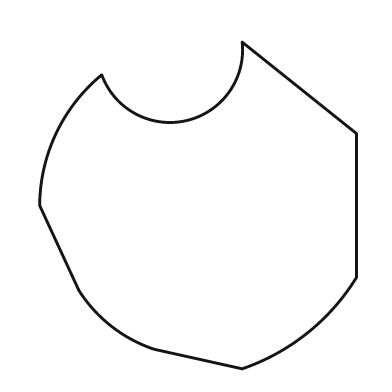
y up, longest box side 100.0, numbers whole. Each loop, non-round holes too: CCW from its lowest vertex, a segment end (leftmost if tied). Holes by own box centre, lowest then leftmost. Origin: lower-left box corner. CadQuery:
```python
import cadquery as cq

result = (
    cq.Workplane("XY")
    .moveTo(62.0, 0.0)
    .threePointArc((82.0, 11.0), (97.0, 28.0))
    .lineTo(97.0, 72.0)
    .lineTo(62.0, 100.0)
    .threePointArc((45.0, 76.0), (19.0, 90.0))
    .threePointArc((5.0, 72.0), (0.0, 50.0))
    .lineTo(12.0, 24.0)
    .threePointArc((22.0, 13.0), (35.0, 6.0))
    .close()
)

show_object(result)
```